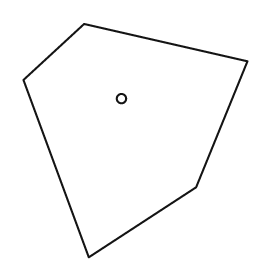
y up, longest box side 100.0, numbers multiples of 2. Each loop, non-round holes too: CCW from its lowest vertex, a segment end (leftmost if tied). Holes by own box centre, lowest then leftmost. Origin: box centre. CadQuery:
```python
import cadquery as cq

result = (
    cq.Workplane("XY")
    .moveTo(-20.0, -50.0)
    .lineTo(26.0, -20.0)
    .lineTo(48.0, 34.0)
    .lineTo(-22.0, 50.0)
    .lineTo(-48.0, 26.0)
    .close()
    .moveTo(-6.0, 18.0)
    .circle(2.0)
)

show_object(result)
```